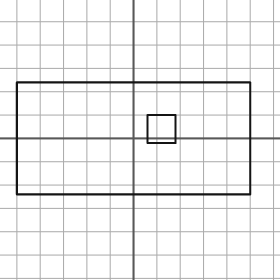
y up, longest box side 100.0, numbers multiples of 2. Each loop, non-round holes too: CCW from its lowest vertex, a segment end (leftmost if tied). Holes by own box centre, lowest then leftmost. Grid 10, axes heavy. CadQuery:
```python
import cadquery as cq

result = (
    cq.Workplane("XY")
    .moveTo(-50.0, -24.0)
    .lineTo(50.0, -24.0)
    .lineTo(50.0, 24.0)
    .lineTo(-50.0, 24.0)
    .close()
    .moveTo(6.0, -2.0)
    .lineTo(18.0, -2.0)
    .lineTo(18.0, 10.0)
    .lineTo(6.0, 10.0)
    .close()
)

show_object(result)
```